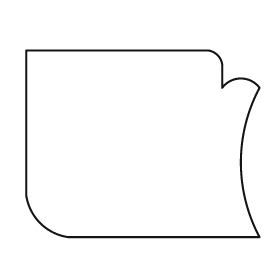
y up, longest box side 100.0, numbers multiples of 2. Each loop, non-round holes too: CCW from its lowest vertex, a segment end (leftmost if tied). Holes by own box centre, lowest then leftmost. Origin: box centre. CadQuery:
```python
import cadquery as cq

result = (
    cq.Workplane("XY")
    .moveTo(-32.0, -40.0)
    .lineTo(50.0, -40.0)
    .threePointArc((42.0, -8.0), (50.0, 24.0))
    .threePointArc((42.0, 28.0), (34.0, 24.0))
    .lineTo(34.0, 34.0)
    .threePointArc((32.0, 38.0), (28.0, 40.0))
    .lineTo(-50.0, 40.0)
    .lineTo(-50.0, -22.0)
    .threePointArc((-44.0, -34.0), (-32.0, -40.0))
    .close()
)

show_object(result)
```